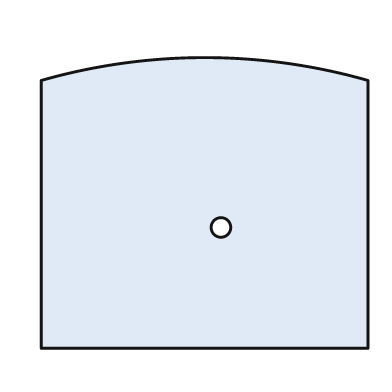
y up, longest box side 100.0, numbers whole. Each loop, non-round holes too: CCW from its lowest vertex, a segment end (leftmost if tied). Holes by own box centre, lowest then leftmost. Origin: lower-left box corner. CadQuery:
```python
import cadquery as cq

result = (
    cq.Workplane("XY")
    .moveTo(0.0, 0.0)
    .lineTo(100.0, 0.0)
    .lineTo(100.0, 82.0)
    .threePointArc((50.0, 89.0), (0.0, 82.0))
    .close()
    .moveTo(55.0, 37.0)
    .circle(3.0)
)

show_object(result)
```